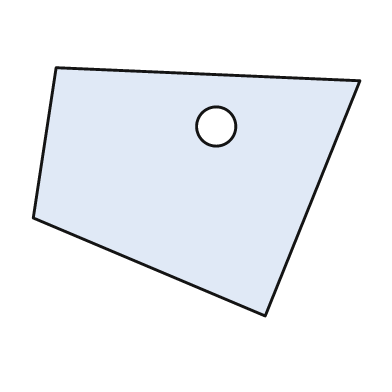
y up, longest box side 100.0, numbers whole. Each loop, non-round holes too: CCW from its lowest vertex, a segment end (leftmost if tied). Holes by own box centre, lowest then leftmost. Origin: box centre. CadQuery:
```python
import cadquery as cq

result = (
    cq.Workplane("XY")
    .moveTo(21.0, -38.0)
    .lineTo(50.0, 34.0)
    .lineTo(-43.0, 38.0)
    .lineTo(-50.0, -8.0)
    .close()
    .moveTo(6.0, 20.0)
    .circle(6.0)
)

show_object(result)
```